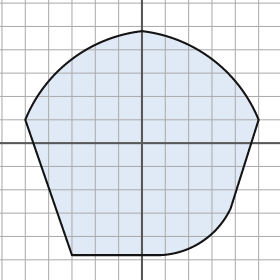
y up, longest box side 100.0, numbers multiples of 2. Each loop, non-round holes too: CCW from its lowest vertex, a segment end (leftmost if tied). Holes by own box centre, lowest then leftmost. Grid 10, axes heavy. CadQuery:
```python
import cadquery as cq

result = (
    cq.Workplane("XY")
    .moveTo(-30.0, -48.0)
    .lineTo(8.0, -48.0)
    .threePointArc((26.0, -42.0), (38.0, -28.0))
    .lineTo(50.0, 10.0)
    .threePointArc((30.0, 36.0), (0.0, 48.0))
    .threePointArc((-30.0, 36.0), (-50.0, 10.0))
    .close()
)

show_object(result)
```